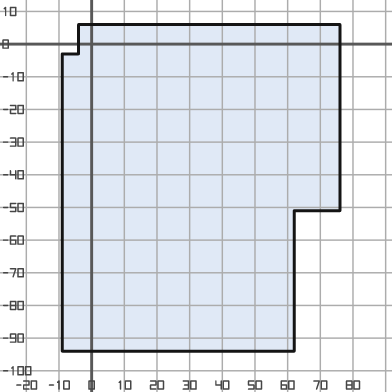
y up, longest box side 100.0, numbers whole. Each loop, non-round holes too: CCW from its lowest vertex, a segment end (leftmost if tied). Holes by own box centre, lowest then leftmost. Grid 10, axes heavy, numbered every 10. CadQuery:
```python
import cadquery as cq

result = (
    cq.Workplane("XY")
    .moveTo(-9.0, -94.0)
    .lineTo(62.0, -94.0)
    .lineTo(62.0, -51.0)
    .lineTo(76.0, -51.0)
    .lineTo(76.0, 6.0)
    .lineTo(-4.0, 6.0)
    .lineTo(-4.0, -3.0)
    .lineTo(-9.0, -3.0)
    .close()
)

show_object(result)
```